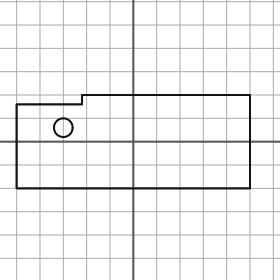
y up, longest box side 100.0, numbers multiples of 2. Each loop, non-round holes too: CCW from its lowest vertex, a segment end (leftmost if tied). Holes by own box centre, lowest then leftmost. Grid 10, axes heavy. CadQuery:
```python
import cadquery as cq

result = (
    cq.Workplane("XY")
    .moveTo(-50.0, -20.0)
    .lineTo(50.0, -20.0)
    .lineTo(50.0, 20.0)
    .lineTo(-22.0, 20.0)
    .lineTo(-22.0, 16.0)
    .lineTo(-50.0, 16.0)
    .close()
    .moveTo(-30.0, 6.0)
    .circle(4.0)
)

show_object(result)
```